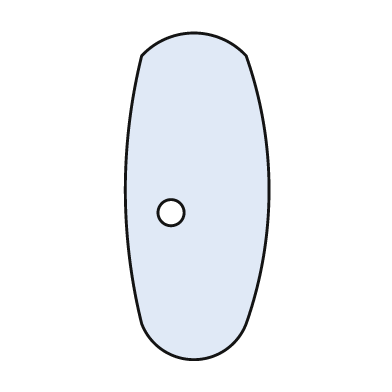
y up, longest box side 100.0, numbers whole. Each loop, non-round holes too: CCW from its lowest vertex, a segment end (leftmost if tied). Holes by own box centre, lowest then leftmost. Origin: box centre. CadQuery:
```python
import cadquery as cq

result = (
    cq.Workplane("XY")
    .moveTo(-17.0, -39.0)
    .threePointArc((-1.0, -50.0), (15.0, -39.0))
    .threePointArc((22.0, 2.0), (15.0, 43.0))
    .threePointArc((-1.0, 50.0), (-17.0, 43.0))
    .threePointArc((-22.0, 2.0), (-17.0, -39.0))
    .close()
    .moveTo(-8.0, -5.0)
    .circle(4.0)
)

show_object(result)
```